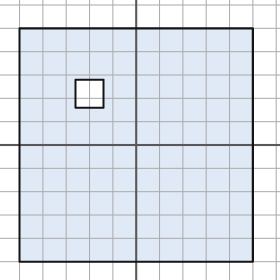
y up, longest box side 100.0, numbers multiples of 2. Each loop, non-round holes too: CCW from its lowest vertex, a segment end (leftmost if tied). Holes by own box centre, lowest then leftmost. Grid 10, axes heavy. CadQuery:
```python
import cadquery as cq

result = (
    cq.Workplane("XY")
    .moveTo(-50.0, -50.0)
    .lineTo(50.0, -50.0)
    .lineTo(50.0, 50.0)
    .lineTo(-50.0, 50.0)
    .close()
    .moveTo(-26.0, 16.0)
    .lineTo(-14.0, 16.0)
    .lineTo(-14.0, 28.0)
    .lineTo(-26.0, 28.0)
    .close()
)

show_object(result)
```